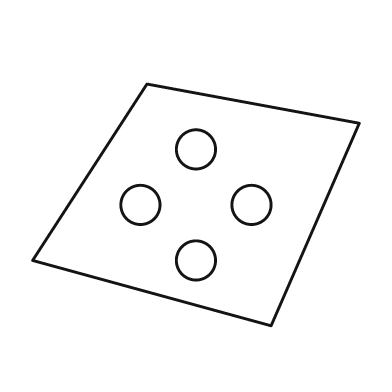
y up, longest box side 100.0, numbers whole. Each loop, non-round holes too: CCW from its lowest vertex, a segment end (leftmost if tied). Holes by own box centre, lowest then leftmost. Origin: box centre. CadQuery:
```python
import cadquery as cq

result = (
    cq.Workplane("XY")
    .moveTo(23.0, -37.0)
    .lineTo(50.0, 25.0)
    .lineTo(-15.0, 37.0)
    .lineTo(-50.0, -17.0)
    .close()
    .moveTo(0.0, -17.0)
    .circle(6.0)
    .moveTo(-17.0, 0.0)
    .circle(6.0)
    .moveTo(17.0, 0.0)
    .circle(6.0)
    .moveTo(0.0, 17.0)
    .circle(6.0)
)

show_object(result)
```